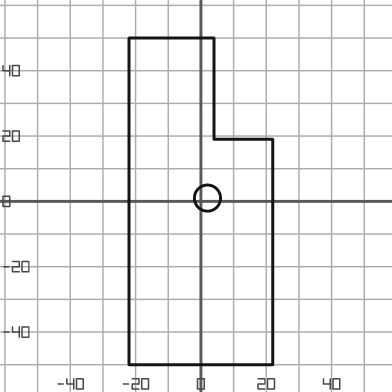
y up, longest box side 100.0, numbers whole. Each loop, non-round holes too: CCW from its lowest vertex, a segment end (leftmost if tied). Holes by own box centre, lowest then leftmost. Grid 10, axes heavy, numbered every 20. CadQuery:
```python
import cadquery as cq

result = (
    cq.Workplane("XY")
    .moveTo(-22.0, -50.0)
    .lineTo(22.0, -50.0)
    .lineTo(22.0, 19.0)
    .lineTo(4.0, 19.0)
    .lineTo(4.0, 50.0)
    .lineTo(-22.0, 50.0)
    .close()
    .moveTo(2.0, 1.0)
    .circle(4.0)
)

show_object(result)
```